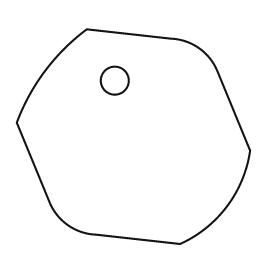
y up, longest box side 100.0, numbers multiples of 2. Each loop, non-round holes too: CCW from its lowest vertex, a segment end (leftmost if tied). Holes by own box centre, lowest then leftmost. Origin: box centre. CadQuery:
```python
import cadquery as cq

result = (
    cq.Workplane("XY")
    .moveTo(20.0, -46.0)
    .threePointArc((40.0, -30.0), (50.0, -6.0))
    .lineTo(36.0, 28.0)
    .threePointArc((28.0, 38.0), (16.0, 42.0))
    .lineTo(-20.0, 46.0)
    .threePointArc((-38.0, 28.0), (-50.0, 6.0))
    .lineTo(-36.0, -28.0)
    .threePointArc((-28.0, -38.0), (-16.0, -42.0))
    .close()
    .moveTo(-8.0, 24.0)
    .circle(6.0)
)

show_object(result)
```